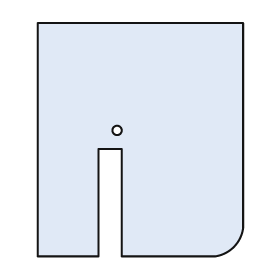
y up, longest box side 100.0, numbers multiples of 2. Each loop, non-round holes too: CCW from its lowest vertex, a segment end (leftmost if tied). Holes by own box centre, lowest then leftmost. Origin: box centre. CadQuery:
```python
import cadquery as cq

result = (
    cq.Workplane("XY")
    .moveTo(-44.0, -50.0)
    .lineTo(-18.0, -50.0)
    .lineTo(-18.0, -4.0)
    .lineTo(-8.0, -4.0)
    .lineTo(-8.0, -50.0)
    .lineTo(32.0, -50.0)
    .threePointArc((40.0, -46.0), (44.0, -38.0))
    .lineTo(44.0, 50.0)
    .lineTo(-44.0, 50.0)
    .close()
    .moveTo(-10.0, 4.0)
    .circle(2.0)
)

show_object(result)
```